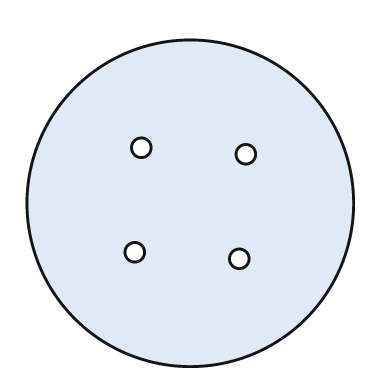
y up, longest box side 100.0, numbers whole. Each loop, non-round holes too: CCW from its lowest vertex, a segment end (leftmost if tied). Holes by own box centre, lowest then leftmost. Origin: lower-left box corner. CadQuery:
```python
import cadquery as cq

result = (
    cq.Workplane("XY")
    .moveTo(50.0, 50.0)
    .circle(50.0)
    .moveTo(65.0, 33.0)
    .circle(3.0)
    .moveTo(33.0, 35.0)
    .circle(3.0)
    .moveTo(67.0, 65.0)
    .circle(3.0)
    .moveTo(35.0, 67.0)
    .circle(3.0)
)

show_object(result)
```